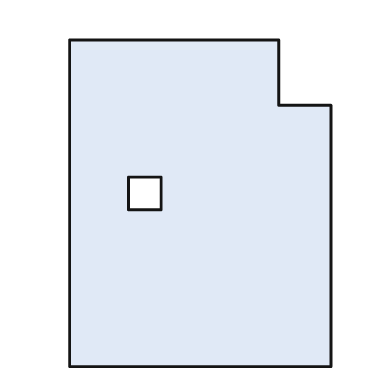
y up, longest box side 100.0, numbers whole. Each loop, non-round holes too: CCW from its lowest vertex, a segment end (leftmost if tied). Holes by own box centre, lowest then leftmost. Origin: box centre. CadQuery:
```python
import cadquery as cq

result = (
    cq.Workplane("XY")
    .moveTo(-40.0, -50.0)
    .lineTo(40.0, -50.0)
    .lineTo(40.0, 30.0)
    .lineTo(24.0, 30.0)
    .lineTo(24.0, 50.0)
    .lineTo(-40.0, 50.0)
    .close()
    .moveTo(-22.0, -2.0)
    .lineTo(-12.0, -2.0)
    .lineTo(-12.0, 8.0)
    .lineTo(-22.0, 8.0)
    .close()
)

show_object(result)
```